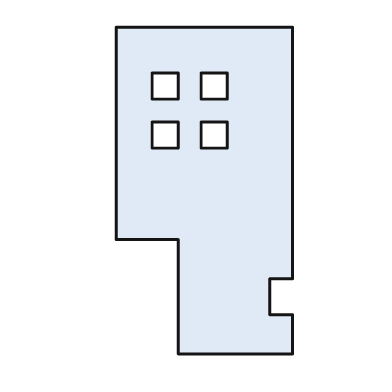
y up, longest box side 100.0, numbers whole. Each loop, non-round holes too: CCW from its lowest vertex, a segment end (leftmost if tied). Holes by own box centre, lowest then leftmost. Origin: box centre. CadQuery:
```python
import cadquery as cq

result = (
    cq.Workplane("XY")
    .moveTo(-8.0, -50.0)
    .lineTo(27.0, -50.0)
    .lineTo(27.0, -38.0)
    .lineTo(20.0, -38.0)
    .lineTo(20.0, -27.0)
    .lineTo(27.0, -27.0)
    .lineTo(27.0, 50.0)
    .lineTo(-27.0, 50.0)
    .lineTo(-27.0, -15.0)
    .lineTo(-8.0, -15.0)
    .close()
    .moveTo(-16.0, 13.0)
    .lineTo(-8.0, 13.0)
    .lineTo(-8.0, 21.0)
    .lineTo(-16.0, 21.0)
    .close()
    .moveTo(-1.0, 13.0)
    .lineTo(7.0, 13.0)
    .lineTo(7.0, 21.0)
    .lineTo(-1.0, 21.0)
    .close()
    .moveTo(-16.0, 28.0)
    .lineTo(-8.0, 28.0)
    .lineTo(-8.0, 36.0)
    .lineTo(-16.0, 36.0)
    .close()
    .moveTo(-1.0, 28.0)
    .lineTo(7.0, 28.0)
    .lineTo(7.0, 36.0)
    .lineTo(-1.0, 36.0)
    .close()
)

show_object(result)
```